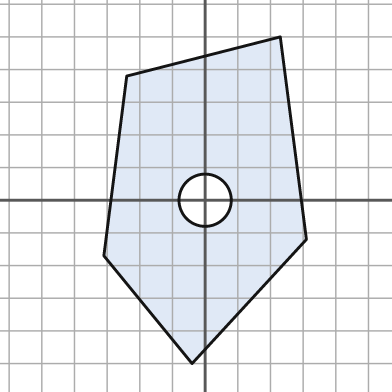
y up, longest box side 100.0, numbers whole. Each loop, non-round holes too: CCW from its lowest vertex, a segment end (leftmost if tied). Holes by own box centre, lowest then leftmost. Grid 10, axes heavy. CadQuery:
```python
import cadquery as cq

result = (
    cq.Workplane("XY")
    .moveTo(-4.0, -50.0)
    .lineTo(31.0, -12.0)
    .lineTo(23.0, 50.0)
    .lineTo(-24.0, 38.0)
    .lineTo(-31.0, -17.0)
    .close()
    .moveTo(0.0, 0.0)
    .circle(8.0)
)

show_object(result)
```